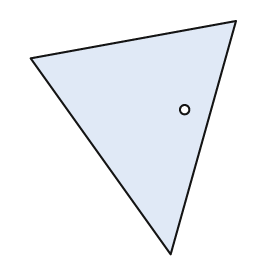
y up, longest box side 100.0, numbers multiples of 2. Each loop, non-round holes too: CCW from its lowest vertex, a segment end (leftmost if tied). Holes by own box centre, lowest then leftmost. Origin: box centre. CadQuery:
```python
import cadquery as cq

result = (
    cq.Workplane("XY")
    .moveTo(16.0, -50.0)
    .lineTo(44.0, 50.0)
    .lineTo(-44.0, 34.0)
    .close()
    .moveTo(22.0, 12.0)
    .circle(2.0)
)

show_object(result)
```